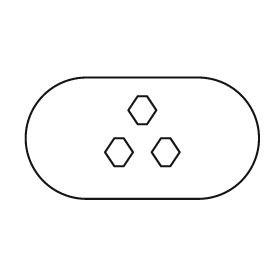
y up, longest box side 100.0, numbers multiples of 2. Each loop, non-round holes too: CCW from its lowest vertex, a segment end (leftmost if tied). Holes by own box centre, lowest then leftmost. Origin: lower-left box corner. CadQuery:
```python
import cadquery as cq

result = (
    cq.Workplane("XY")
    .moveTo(26.0, 0.0)
    .lineTo(74.0, 0.0)
    .threePointArc((100.0, 26.0), (74.0, 52.0))
    .lineTo(26.0, 52.0)
    .threePointArc((0.0, 26.0), (26.0, 0.0))
    .close()
    .moveTo(38.0, 14.0)
    .lineTo(42.0, 14.0)
    .lineTo(46.0, 20.0)
    .lineTo(42.0, 26.0)
    .lineTo(38.0, 26.0)
    .lineTo(34.0, 20.0)
    .close()
    .moveTo(58.0, 14.0)
    .lineTo(62.0, 14.0)
    .lineTo(66.0, 20.0)
    .lineTo(62.0, 26.0)
    .lineTo(58.0, 26.0)
    .lineTo(54.0, 20.0)
    .close()
    .moveTo(48.0, 32.0)
    .lineTo(52.0, 32.0)
    .lineTo(56.0, 38.0)
    .lineTo(52.0, 44.0)
    .lineTo(48.0, 44.0)
    .lineTo(44.0, 38.0)
    .close()
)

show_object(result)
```